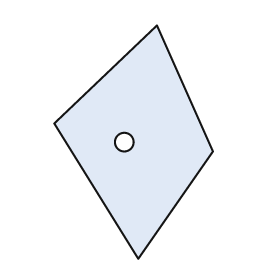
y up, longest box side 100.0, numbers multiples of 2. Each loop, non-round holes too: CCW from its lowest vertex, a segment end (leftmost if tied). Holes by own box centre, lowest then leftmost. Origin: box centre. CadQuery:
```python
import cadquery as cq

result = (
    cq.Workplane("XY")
    .moveTo(2.0, -50.0)
    .lineTo(34.0, -4.0)
    .lineTo(10.0, 50.0)
    .lineTo(-34.0, 8.0)
    .close()
    .moveTo(-4.0, 0.0)
    .circle(4.0)
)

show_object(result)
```